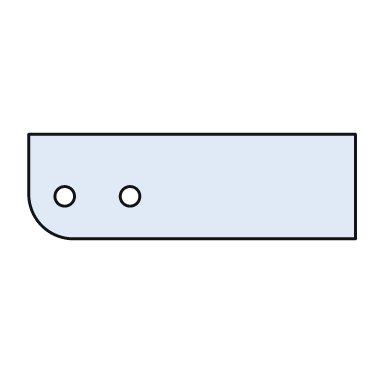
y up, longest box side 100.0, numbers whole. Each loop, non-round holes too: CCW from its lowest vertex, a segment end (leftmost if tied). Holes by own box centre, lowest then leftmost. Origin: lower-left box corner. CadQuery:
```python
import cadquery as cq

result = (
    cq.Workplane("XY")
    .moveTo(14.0, 0.0)
    .lineTo(100.0, 0.0)
    .lineTo(100.0, 32.0)
    .lineTo(0.0, 32.0)
    .lineTo(0.0, 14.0)
    .threePointArc((4.0, 4.0), (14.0, 0.0))
    .close()
    .moveTo(11.0, 13.0)
    .circle(3.0)
    .moveTo(31.0, 13.0)
    .circle(3.0)
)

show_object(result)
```